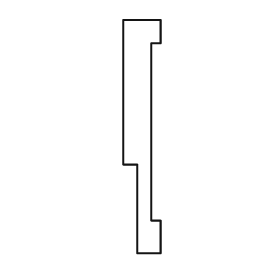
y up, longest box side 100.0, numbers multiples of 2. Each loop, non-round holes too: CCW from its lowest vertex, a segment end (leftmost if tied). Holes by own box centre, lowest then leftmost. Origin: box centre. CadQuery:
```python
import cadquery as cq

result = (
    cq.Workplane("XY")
    .moveTo(-2.0, -50.0)
    .lineTo(8.0, -50.0)
    .lineTo(8.0, -36.0)
    .lineTo(4.0, -36.0)
    .lineTo(4.0, 40.0)
    .lineTo(8.0, 40.0)
    .lineTo(8.0, 50.0)
    .lineTo(-8.0, 50.0)
    .lineTo(-8.0, -12.0)
    .lineTo(-2.0, -12.0)
    .close()
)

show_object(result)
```